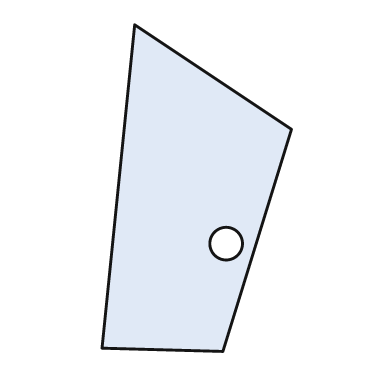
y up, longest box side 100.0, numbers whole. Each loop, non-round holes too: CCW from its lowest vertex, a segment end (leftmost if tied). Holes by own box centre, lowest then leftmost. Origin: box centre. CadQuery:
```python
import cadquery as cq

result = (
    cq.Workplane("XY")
    .moveTo(8.0, -50.0)
    .lineTo(29.0, 18.0)
    .lineTo(-19.0, 50.0)
    .lineTo(-29.0, -49.0)
    .close()
    .moveTo(9.0, -17.0)
    .circle(5.0)
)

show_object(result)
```